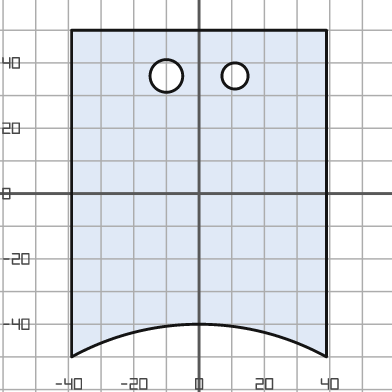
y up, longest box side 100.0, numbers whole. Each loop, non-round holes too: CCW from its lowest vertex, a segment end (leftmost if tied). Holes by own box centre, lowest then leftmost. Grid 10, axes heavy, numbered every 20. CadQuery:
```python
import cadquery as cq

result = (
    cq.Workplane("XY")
    .moveTo(-39.0, -50.0)
    .threePointArc((0.0, -40.0), (39.0, -50.0))
    .lineTo(39.0, 50.0)
    .lineTo(-39.0, 50.0)
    .close()
    .moveTo(-10.0, 36.0)
    .circle(5.0)
    .moveTo(11.0, 36.0)
    .circle(4.0)
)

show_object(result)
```